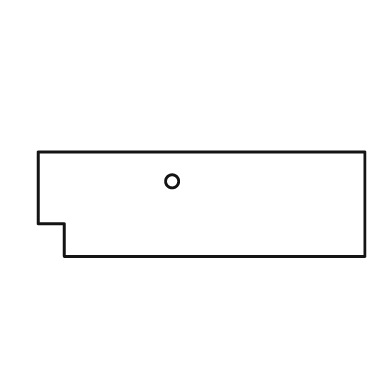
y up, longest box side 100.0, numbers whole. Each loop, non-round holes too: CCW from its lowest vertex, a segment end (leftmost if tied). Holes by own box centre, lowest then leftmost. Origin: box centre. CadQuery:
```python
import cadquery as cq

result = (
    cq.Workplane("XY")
    .moveTo(-42.0, -16.0)
    .lineTo(50.0, -16.0)
    .lineTo(50.0, 16.0)
    .lineTo(-50.0, 16.0)
    .lineTo(-50.0, -6.0)
    .lineTo(-42.0, -6.0)
    .close()
    .moveTo(-9.0, 7.0)
    .circle(2.0)
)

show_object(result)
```